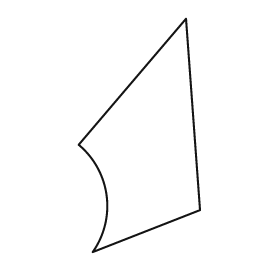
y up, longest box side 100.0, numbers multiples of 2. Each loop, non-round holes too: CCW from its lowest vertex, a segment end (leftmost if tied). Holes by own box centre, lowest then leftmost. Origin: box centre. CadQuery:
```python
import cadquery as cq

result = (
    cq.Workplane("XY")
    .moveTo(-20.0, -50.0)
    .lineTo(26.0, -32.0)
    .lineTo(20.0, 50.0)
    .lineTo(-26.0, -4.0)
    .threePointArc((-14.0, -26.0), (-20.0, -50.0))
    .close()
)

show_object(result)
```